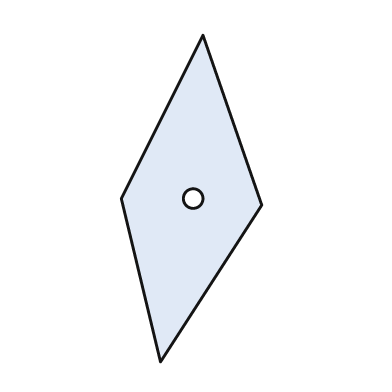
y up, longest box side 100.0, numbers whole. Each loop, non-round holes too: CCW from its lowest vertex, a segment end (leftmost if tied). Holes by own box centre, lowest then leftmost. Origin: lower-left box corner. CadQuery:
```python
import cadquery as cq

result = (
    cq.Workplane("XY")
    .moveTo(12.0, 0.0)
    .lineTo(43.0, 48.0)
    .lineTo(25.0, 100.0)
    .lineTo(0.0, 50.0)
    .close()
    .moveTo(22.0, 50.0)
    .circle(3.0)
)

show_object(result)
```